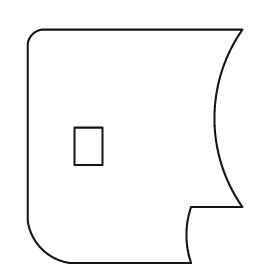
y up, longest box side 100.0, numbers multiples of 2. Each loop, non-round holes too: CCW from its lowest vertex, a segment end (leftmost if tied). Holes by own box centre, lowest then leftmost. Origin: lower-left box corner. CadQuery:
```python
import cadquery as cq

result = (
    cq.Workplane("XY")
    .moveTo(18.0, 0.0)
    .lineTo(70.0, 0.0)
    .threePointArc((68.0, 12.0), (70.0, 24.0))
    .lineTo(92.0, 24.0)
    .threePointArc((80.0, 62.0), (92.0, 100.0))
    .lineTo(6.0, 100.0)
    .threePointArc((2.0, 98.0), (0.0, 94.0))
    .lineTo(0.0, 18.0)
    .threePointArc((6.0, 6.0), (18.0, 0.0))
    .close()
    .moveTo(20.0, 42.0)
    .lineTo(32.0, 42.0)
    .lineTo(32.0, 58.0)
    .lineTo(20.0, 58.0)
    .close()
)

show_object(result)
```